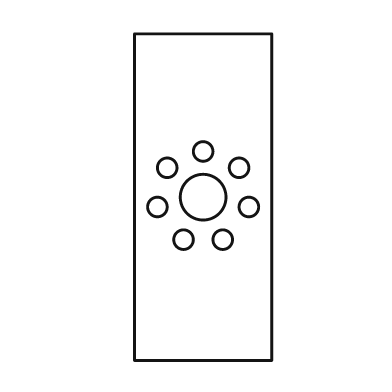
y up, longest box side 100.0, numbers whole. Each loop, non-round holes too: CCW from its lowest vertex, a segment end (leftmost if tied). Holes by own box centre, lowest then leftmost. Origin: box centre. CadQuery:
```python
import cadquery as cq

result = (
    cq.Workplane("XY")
    .moveTo(-21.0, -50.0)
    .lineTo(21.0, -50.0)
    .lineTo(21.0, 50.0)
    .lineTo(-21.0, 50.0)
    .close()
    .moveTo(-6.0, -13.0)
    .circle(3.0)
    .moveTo(6.0, -13.0)
    .circle(3.0)
    .moveTo(-14.0, -3.0)
    .circle(3.0)
    .moveTo(14.0, -3.0)
    .circle(3.0)
    .moveTo(0.0, 0.0)
    .circle(7.0)
    .moveTo(-11.0, 9.0)
    .circle(3.0)
    .moveTo(11.0, 9.0)
    .circle(3.0)
    .moveTo(0.0, 14.0)
    .circle(3.0)
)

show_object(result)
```